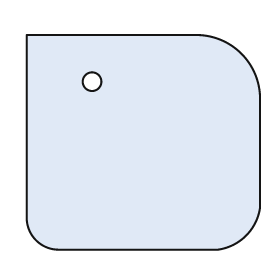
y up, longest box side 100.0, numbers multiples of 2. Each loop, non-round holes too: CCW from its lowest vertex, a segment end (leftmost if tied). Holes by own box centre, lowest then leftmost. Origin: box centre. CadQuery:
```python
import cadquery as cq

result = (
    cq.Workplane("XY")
    .moveTo(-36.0, -46.0)
    .lineTo(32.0, -46.0)
    .threePointArc((44.0, -40.0), (50.0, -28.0))
    .lineTo(50.0, 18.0)
    .threePointArc((42.0, 38.0), (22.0, 46.0))
    .lineTo(-50.0, 46.0)
    .lineTo(-50.0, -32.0)
    .threePointArc((-46.0, -42.0), (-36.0, -46.0))
    .close()
    .moveTo(-22.0, 26.0)
    .circle(4.0)
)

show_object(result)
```